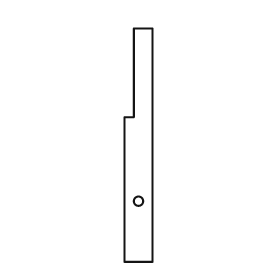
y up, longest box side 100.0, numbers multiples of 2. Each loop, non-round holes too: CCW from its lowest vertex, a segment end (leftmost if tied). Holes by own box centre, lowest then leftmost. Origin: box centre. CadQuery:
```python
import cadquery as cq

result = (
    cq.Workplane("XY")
    .moveTo(-6.0, -50.0)
    .lineTo(6.0, -50.0)
    .lineTo(6.0, 50.0)
    .lineTo(-2.0, 50.0)
    .lineTo(-2.0, 12.0)
    .lineTo(-6.0, 12.0)
    .close()
    .moveTo(0.0, -24.0)
    .circle(2.0)
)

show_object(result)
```